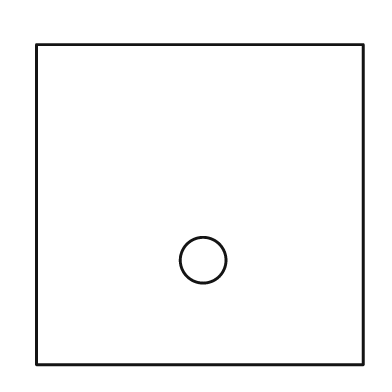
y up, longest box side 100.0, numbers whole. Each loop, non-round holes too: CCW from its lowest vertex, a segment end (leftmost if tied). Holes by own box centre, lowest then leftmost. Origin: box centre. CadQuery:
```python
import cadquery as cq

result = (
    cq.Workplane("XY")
    .moveTo(-50.0, -49.0)
    .lineTo(50.0, -49.0)
    .lineTo(50.0, 49.0)
    .lineTo(-50.0, 49.0)
    .close()
    .moveTo(1.0, -17.0)
    .circle(7.0)
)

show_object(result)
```